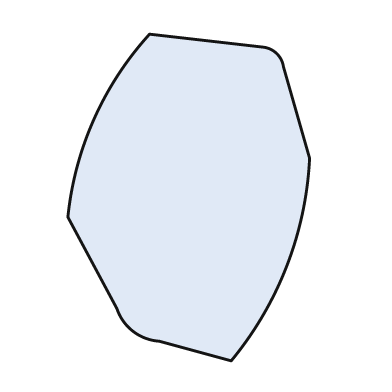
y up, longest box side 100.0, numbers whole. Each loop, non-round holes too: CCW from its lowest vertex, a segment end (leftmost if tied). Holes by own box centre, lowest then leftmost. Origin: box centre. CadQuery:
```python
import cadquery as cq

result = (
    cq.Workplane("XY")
    .moveTo(13.0, -50.0)
    .threePointArc((30.0, -21.0), (37.0, 12.0))
    .lineTo(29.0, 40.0)
    .threePointArc((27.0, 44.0), (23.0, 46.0))
    .lineTo(-12.0, 50.0)
    .threePointArc((-29.0, 24.0), (-37.0, -6.0))
    .lineTo(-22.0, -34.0)
    .threePointArc((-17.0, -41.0), (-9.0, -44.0))
    .close()
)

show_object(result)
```